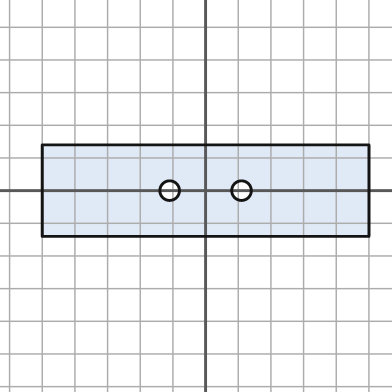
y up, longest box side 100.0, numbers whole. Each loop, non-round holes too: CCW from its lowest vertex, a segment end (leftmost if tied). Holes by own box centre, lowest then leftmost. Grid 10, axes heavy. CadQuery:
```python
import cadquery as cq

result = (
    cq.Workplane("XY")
    .moveTo(-50.0, -14.0)
    .lineTo(50.0, -14.0)
    .lineTo(50.0, 14.0)
    .lineTo(-50.0, 14.0)
    .close()
    .moveTo(-11.0, 0.0)
    .circle(3.0)
    .moveTo(11.0, 0.0)
    .circle(3.0)
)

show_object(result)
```